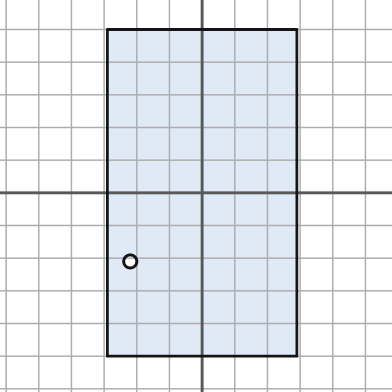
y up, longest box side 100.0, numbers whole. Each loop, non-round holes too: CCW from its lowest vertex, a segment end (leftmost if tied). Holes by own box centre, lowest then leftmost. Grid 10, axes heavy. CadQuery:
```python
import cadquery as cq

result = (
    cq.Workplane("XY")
    .moveTo(-29.0, -50.0)
    .lineTo(29.0, -50.0)
    .lineTo(29.0, 50.0)
    .lineTo(-29.0, 50.0)
    .close()
    .moveTo(-22.0, -21.0)
    .circle(2.0)
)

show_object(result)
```